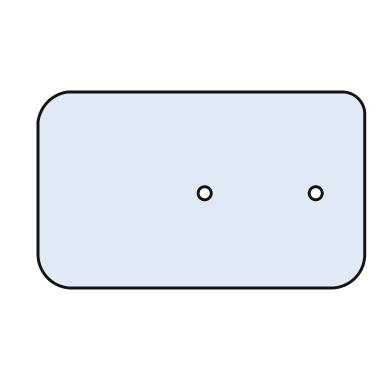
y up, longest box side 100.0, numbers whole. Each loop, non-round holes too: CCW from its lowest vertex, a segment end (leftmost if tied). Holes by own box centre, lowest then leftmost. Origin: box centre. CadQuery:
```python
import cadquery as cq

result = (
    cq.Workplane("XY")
    .moveTo(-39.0, -30.0)
    .lineTo(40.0, -30.0)
    .threePointArc((47.0, -27.0), (50.0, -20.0))
    .lineTo(50.0, 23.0)
    .threePointArc((48.0, 28.0), (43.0, 30.0))
    .lineTo(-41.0, 30.0)
    .threePointArc((-47.0, 27.0), (-50.0, 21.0))
    .lineTo(-50.0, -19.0)
    .threePointArc((-47.0, -27.0), (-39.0, -30.0))
    .close()
    .moveTo(1.0, -1.0)
    .circle(2.0)
    .moveTo(35.0, -1.0)
    .circle(2.0)
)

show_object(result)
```